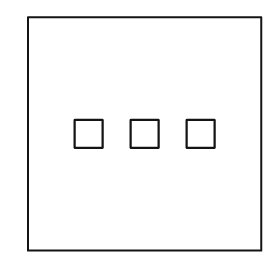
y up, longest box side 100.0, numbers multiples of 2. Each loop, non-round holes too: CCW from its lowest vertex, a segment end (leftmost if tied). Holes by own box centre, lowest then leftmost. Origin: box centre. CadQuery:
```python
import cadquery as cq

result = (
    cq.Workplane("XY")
    .moveTo(-50.0, -50.0)
    .lineTo(50.0, -50.0)
    .lineTo(50.0, 50.0)
    .lineTo(-50.0, 50.0)
    .close()
    .moveTo(-30.0, -6.0)
    .lineTo(-18.0, -6.0)
    .lineTo(-18.0, 6.0)
    .lineTo(-30.0, 6.0)
    .close()
    .moveTo(-6.0, -6.0)
    .lineTo(6.0, -6.0)
    .lineTo(6.0, 6.0)
    .lineTo(-6.0, 6.0)
    .close()
    .moveTo(18.0, -6.0)
    .lineTo(30.0, -6.0)
    .lineTo(30.0, 6.0)
    .lineTo(18.0, 6.0)
    .close()
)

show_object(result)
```